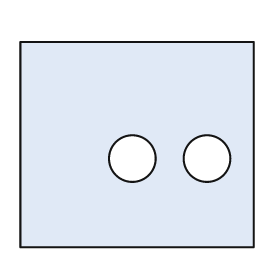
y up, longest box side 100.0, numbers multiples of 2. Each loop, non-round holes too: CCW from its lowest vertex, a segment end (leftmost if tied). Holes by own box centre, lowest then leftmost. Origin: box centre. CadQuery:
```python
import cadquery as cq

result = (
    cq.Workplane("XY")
    .moveTo(-50.0, -44.0)
    .lineTo(50.0, -44.0)
    .lineTo(50.0, 44.0)
    .lineTo(-50.0, 44.0)
    .close()
    .moveTo(-2.0, -6.0)
    .circle(10.0)
    .moveTo(30.0, -6.0)
    .circle(10.0)
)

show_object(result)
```